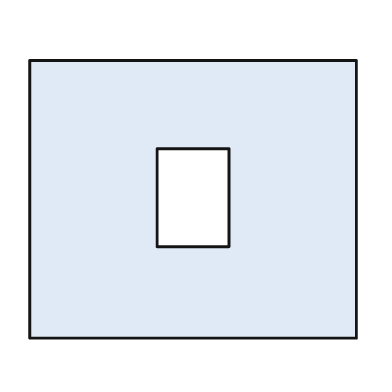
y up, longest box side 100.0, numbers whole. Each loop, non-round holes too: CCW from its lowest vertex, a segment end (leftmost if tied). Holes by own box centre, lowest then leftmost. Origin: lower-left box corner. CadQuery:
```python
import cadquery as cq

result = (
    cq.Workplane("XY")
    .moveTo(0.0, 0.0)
    .lineTo(100.0, 0.0)
    .lineTo(100.0, 85.0)
    .lineTo(0.0, 85.0)
    .close()
    .moveTo(39.0, 28.0)
    .lineTo(61.0, 28.0)
    .lineTo(61.0, 58.0)
    .lineTo(39.0, 58.0)
    .close()
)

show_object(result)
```